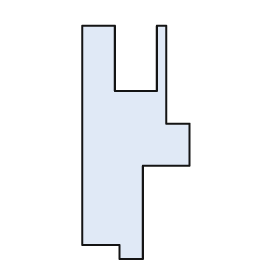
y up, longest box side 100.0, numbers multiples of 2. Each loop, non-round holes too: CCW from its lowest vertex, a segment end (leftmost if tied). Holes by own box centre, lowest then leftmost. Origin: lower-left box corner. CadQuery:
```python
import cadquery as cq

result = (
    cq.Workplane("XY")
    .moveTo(16.0, 0.0)
    .lineTo(26.0, 0.0)
    .lineTo(26.0, 40.0)
    .lineTo(46.0, 40.0)
    .lineTo(46.0, 58.0)
    .lineTo(36.0, 58.0)
    .lineTo(36.0, 100.0)
    .lineTo(32.0, 100.0)
    .lineTo(32.0, 72.0)
    .lineTo(14.0, 72.0)
    .lineTo(14.0, 100.0)
    .lineTo(0.0, 100.0)
    .lineTo(0.0, 6.0)
    .lineTo(16.0, 6.0)
    .close()
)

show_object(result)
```